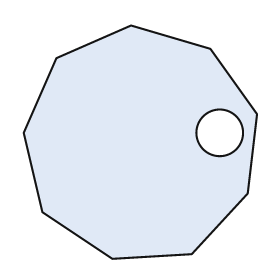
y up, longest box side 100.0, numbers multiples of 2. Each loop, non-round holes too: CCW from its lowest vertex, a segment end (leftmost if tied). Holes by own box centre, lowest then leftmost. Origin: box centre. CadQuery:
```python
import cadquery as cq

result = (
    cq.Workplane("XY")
    .moveTo(-12.0, -50.0)
    .lineTo(22.0, -48.0)
    .lineTo(46.0, -22.0)
    .lineTo(50.0, 12.0)
    .lineTo(30.0, 40.0)
    .lineTo(-4.0, 50.0)
    .lineTo(-36.0, 36.0)
    .lineTo(-50.0, 4.0)
    .lineTo(-42.0, -30.0)
    .close()
    .moveTo(34.0, 4.0)
    .circle(10.0)
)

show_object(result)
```